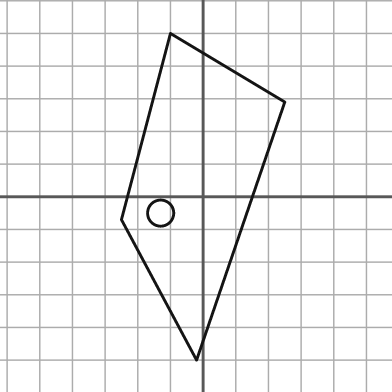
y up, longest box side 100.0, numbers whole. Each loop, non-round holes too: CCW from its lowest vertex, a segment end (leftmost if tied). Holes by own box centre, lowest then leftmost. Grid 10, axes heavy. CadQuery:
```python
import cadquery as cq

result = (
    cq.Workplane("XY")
    .moveTo(-2.0, -50.0)
    .lineTo(25.0, 29.0)
    .lineTo(-10.0, 50.0)
    .lineTo(-25.0, -7.0)
    .close()
    .moveTo(-13.0, -5.0)
    .circle(4.0)
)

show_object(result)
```